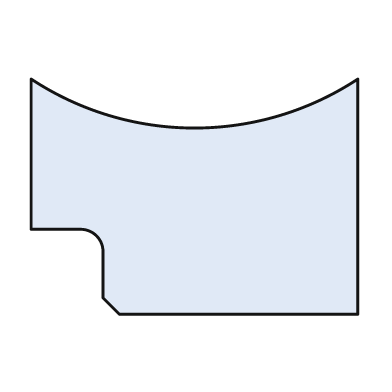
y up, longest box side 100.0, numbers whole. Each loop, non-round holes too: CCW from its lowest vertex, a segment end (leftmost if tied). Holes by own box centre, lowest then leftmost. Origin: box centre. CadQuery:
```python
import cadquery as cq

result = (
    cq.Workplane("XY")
    .moveTo(-23.0, -36.0)
    .lineTo(50.0, -36.0)
    .lineTo(50.0, 36.0)
    .threePointArc((0.0, 21.0), (-50.0, 36.0))
    .lineTo(-50.0, -10.0)
    .lineTo(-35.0, -10.0)
    .threePointArc((-30.0, -12.0), (-28.0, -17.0))
    .lineTo(-28.0, -31.0)
    .close()
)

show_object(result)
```